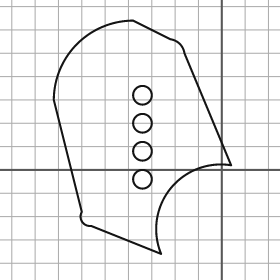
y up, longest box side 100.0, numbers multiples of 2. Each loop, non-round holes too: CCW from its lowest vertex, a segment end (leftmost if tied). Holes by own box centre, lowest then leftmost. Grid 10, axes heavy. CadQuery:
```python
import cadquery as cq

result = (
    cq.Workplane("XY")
    .moveTo(-26.0, -36.0)
    .threePointArc((-22.0, -8.0), (4.0, 2.0))
    .lineTo(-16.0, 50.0)
    .threePointArc((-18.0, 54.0), (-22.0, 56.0))
    .lineTo(-38.0, 64.0)
    .threePointArc((-62.0, 54.0), (-72.0, 30.0))
    .lineTo(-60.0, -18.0)
    .threePointArc((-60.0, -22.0), (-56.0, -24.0))
    .close()
    .moveTo(-34.0, -4.0)
    .circle(4.0)
    .moveTo(-34.0, 8.0)
    .circle(4.0)
    .moveTo(-34.0, 20.0)
    .circle(4.0)
    .moveTo(-34.0, 32.0)
    .circle(4.0)
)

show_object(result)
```